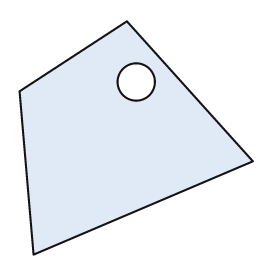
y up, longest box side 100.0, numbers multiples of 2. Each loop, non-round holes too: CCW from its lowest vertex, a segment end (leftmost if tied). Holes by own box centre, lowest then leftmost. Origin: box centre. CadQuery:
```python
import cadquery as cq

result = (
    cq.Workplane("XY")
    .moveTo(-44.0, -50.0)
    .lineTo(50.0, -10.0)
    .lineTo(-4.0, 50.0)
    .lineTo(-50.0, 20.0)
    .close()
    .moveTo(0.0, 24.0)
    .circle(8.0)
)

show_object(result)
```